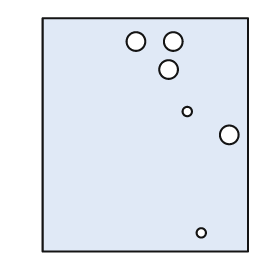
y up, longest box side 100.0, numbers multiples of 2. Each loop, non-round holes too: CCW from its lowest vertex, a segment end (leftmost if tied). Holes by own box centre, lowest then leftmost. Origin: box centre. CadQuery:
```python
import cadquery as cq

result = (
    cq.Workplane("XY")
    .moveTo(-44.0, -50.0)
    .lineTo(44.0, -50.0)
    .lineTo(44.0, 50.0)
    .lineTo(-44.0, 50.0)
    .close()
    .moveTo(24.0, -42.0)
    .circle(2.0)
    .moveTo(36.0, 0.0)
    .circle(4.0)
    .moveTo(18.0, 10.0)
    .circle(2.0)
    .moveTo(10.0, 28.0)
    .circle(4.0)
    .moveTo(-4.0, 40.0)
    .circle(4.0)
    .moveTo(12.0, 40.0)
    .circle(4.0)
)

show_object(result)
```